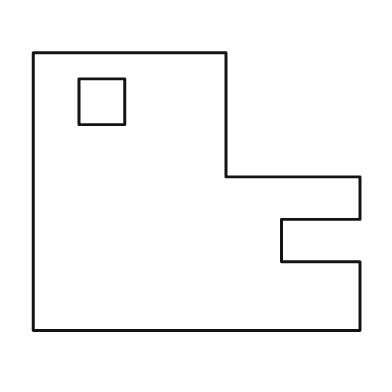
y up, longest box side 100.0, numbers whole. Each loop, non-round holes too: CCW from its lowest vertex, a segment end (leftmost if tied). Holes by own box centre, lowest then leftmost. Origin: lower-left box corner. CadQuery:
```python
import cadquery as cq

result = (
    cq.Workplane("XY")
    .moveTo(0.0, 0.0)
    .lineTo(100.0, 0.0)
    .lineTo(100.0, 21.0)
    .lineTo(76.0, 21.0)
    .lineTo(76.0, 34.0)
    .lineTo(100.0, 34.0)
    .lineTo(100.0, 47.0)
    .lineTo(59.0, 47.0)
    .lineTo(59.0, 85.0)
    .lineTo(0.0, 85.0)
    .close()
    .moveTo(14.0, 63.0)
    .lineTo(28.0, 63.0)
    .lineTo(28.0, 77.0)
    .lineTo(14.0, 77.0)
    .close()
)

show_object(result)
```